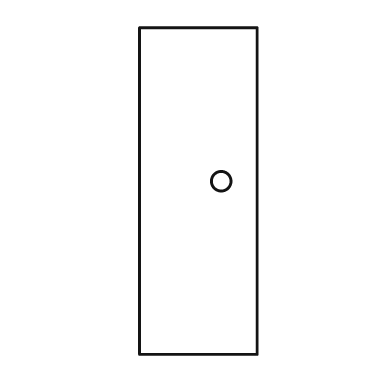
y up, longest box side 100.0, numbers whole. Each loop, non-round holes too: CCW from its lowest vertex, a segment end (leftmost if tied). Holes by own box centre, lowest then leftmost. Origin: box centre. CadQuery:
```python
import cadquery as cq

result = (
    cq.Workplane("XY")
    .moveTo(-18.0, -50.0)
    .lineTo(18.0, -50.0)
    .lineTo(18.0, 50.0)
    .lineTo(-18.0, 50.0)
    .close()
    .moveTo(7.0, 3.0)
    .circle(3.0)
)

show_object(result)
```